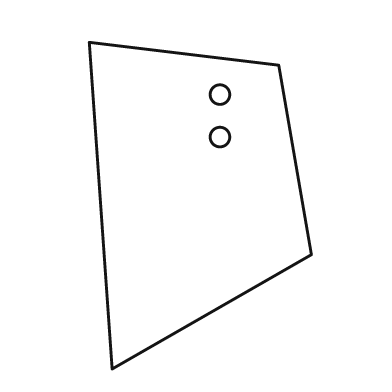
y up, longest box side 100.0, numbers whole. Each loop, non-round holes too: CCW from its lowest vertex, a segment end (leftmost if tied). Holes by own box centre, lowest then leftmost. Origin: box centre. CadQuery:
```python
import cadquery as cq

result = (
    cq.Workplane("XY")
    .moveTo(-27.0, -50.0)
    .lineTo(34.0, -15.0)
    .lineTo(24.0, 43.0)
    .lineTo(-34.0, 50.0)
    .close()
    .moveTo(6.0, 21.0)
    .circle(3.0)
    .moveTo(6.0, 34.0)
    .circle(3.0)
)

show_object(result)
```